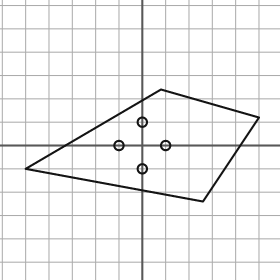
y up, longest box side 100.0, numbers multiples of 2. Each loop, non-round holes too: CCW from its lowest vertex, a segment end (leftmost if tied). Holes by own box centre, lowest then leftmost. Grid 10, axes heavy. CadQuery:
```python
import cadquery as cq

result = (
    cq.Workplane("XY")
    .moveTo(26.0, -24.0)
    .lineTo(50.0, 12.0)
    .lineTo(8.0, 24.0)
    .lineTo(-50.0, -10.0)
    .close()
    .moveTo(0.0, -10.0)
    .circle(2.0)
    .moveTo(-10.0, 0.0)
    .circle(2.0)
    .moveTo(10.0, 0.0)
    .circle(2.0)
    .moveTo(0.0, 10.0)
    .circle(2.0)
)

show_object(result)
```